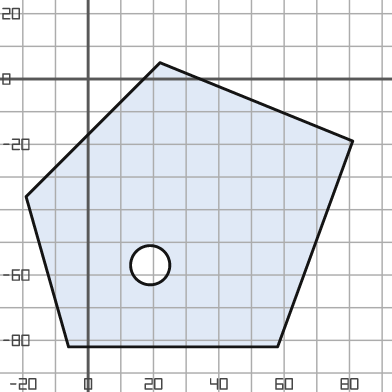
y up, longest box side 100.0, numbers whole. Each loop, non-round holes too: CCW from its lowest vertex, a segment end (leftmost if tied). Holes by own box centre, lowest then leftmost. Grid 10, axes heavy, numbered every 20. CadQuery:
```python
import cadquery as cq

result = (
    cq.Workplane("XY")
    .moveTo(-6.0, -82.0)
    .lineTo(58.0, -82.0)
    .lineTo(81.0, -19.0)
    .lineTo(22.0, 5.0)
    .lineTo(-19.0, -36.0)
    .close()
    .moveTo(19.0, -57.0)
    .circle(6.0)
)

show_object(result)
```